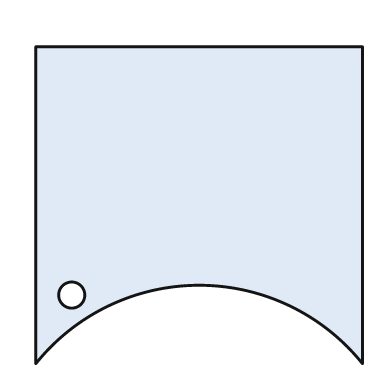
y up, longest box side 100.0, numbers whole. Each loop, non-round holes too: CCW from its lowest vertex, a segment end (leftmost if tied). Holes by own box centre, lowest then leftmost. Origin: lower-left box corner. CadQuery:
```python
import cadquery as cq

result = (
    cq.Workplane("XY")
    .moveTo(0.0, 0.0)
    .threePointArc((50.0, 24.0), (100.0, 0.0))
    .lineTo(100.0, 97.0)
    .lineTo(0.0, 97.0)
    .close()
    .moveTo(11.0, 21.0)
    .circle(4.0)
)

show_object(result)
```